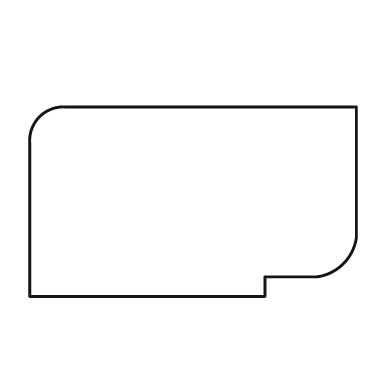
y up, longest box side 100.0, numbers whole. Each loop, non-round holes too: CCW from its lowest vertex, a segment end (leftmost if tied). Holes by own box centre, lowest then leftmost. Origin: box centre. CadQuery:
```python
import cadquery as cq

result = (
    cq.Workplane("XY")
    .moveTo(-50.0, -29.0)
    .lineTo(22.0, -29.0)
    .lineTo(22.0, -23.0)
    .lineTo(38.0, -23.0)
    .threePointArc((46.0, -19.0), (50.0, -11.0))
    .lineTo(50.0, 29.0)
    .lineTo(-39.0, 29.0)
    .threePointArc((-47.0, 26.0), (-50.0, 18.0))
    .close()
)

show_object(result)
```